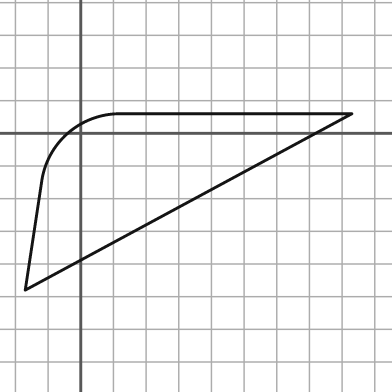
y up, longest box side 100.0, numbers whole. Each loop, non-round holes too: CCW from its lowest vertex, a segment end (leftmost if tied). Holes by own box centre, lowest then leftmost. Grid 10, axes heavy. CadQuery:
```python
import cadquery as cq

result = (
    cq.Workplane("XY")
    .moveTo(-17.0, -48.0)
    .lineTo(83.0, 6.0)
    .lineTo(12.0, 6.0)
    .threePointArc((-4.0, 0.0), (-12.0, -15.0))
    .close()
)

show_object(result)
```